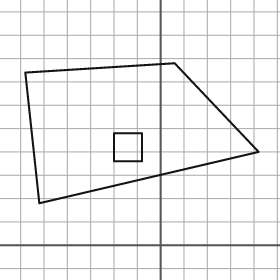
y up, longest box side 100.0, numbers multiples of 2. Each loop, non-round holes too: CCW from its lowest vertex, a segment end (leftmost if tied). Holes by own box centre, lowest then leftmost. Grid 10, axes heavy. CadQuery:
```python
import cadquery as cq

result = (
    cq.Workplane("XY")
    .moveTo(-52.0, 18.0)
    .lineTo(42.0, 40.0)
    .lineTo(6.0, 78.0)
    .lineTo(-58.0, 74.0)
    .close()
    .moveTo(-20.0, 36.0)
    .lineTo(-8.0, 36.0)
    .lineTo(-8.0, 48.0)
    .lineTo(-20.0, 48.0)
    .close()
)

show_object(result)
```